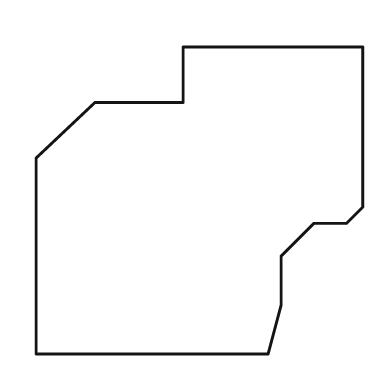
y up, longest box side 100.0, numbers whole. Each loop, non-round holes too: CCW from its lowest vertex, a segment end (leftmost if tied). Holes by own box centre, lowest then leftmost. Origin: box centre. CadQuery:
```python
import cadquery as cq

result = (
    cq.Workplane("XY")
    .moveTo(-50.0, -47.0)
    .lineTo(21.0, -47.0)
    .lineTo(25.0, -32.0)
    .lineTo(25.0, -17.0)
    .lineTo(35.0, -7.0)
    .lineTo(45.0, -7.0)
    .lineTo(50.0, -2.0)
    .lineTo(50.0, 47.0)
    .lineTo(-5.0, 47.0)
    .lineTo(-5.0, 30.0)
    .lineTo(-32.0, 30.0)
    .lineTo(-50.0, 13.0)
    .close()
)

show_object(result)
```